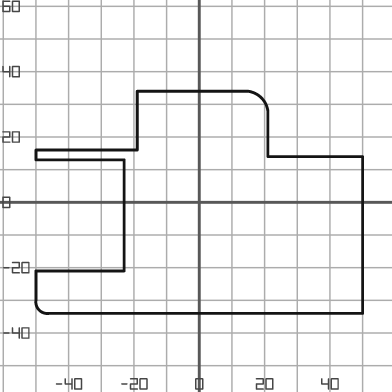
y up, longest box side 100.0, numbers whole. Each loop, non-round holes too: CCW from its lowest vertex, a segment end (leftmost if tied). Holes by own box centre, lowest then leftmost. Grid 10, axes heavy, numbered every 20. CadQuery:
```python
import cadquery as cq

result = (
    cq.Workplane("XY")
    .moveTo(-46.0, -34.0)
    .lineTo(50.0, -34.0)
    .lineTo(50.0, 14.0)
    .lineTo(21.0, 14.0)
    .lineTo(21.0, 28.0)
    .threePointArc((19.0, 32.0), (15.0, 34.0))
    .lineTo(-19.0, 34.0)
    .lineTo(-19.0, 16.0)
    .lineTo(-50.0, 16.0)
    .lineTo(-50.0, 13.0)
    .lineTo(-23.0, 13.0)
    .lineTo(-23.0, -21.0)
    .lineTo(-50.0, -21.0)
    .lineTo(-50.0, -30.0)
    .threePointArc((-49.0, -33.0), (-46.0, -34.0))
    .close()
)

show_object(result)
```